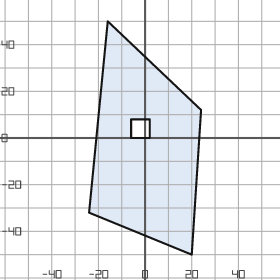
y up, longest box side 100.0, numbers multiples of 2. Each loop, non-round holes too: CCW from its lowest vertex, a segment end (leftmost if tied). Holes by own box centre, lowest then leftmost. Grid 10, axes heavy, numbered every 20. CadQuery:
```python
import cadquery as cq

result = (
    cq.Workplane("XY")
    .moveTo(20.0, -50.0)
    .lineTo(24.0, 12.0)
    .lineTo(-16.0, 50.0)
    .lineTo(-24.0, -32.0)
    .close()
    .moveTo(-6.0, 0.0)
    .lineTo(2.0, 0.0)
    .lineTo(2.0, 8.0)
    .lineTo(-6.0, 8.0)
    .close()
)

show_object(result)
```